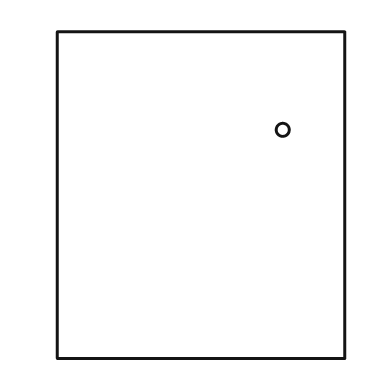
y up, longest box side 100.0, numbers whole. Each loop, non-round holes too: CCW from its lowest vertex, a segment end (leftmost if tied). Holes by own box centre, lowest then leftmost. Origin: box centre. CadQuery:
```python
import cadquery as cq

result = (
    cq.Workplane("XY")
    .moveTo(-44.0, -50.0)
    .lineTo(44.0, -50.0)
    .lineTo(44.0, 50.0)
    .lineTo(-44.0, 50.0)
    .close()
    .moveTo(25.0, 20.0)
    .circle(2.0)
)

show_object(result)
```